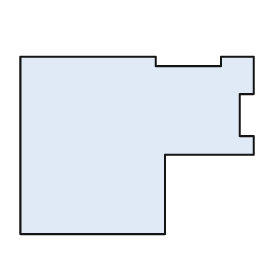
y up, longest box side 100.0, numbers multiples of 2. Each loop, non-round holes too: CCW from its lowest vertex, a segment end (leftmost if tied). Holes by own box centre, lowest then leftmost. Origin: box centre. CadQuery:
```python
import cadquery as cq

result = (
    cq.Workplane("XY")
    .moveTo(-50.0, -38.0)
    .lineTo(12.0, -38.0)
    .lineTo(12.0, -4.0)
    .lineTo(50.0, -4.0)
    .lineTo(50.0, 4.0)
    .lineTo(44.0, 4.0)
    .lineTo(44.0, 22.0)
    .lineTo(50.0, 22.0)
    .lineTo(50.0, 38.0)
    .lineTo(36.0, 38.0)
    .lineTo(36.0, 34.0)
    .lineTo(8.0, 34.0)
    .lineTo(8.0, 38.0)
    .lineTo(-50.0, 38.0)
    .close()
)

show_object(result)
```